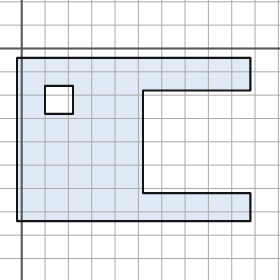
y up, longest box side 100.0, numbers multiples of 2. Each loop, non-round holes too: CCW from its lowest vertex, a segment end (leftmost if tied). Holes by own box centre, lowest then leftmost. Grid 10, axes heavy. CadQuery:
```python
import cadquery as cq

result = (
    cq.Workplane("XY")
    .moveTo(-2.0, -74.0)
    .lineTo(98.0, -74.0)
    .lineTo(98.0, -62.0)
    .lineTo(52.0, -62.0)
    .lineTo(52.0, -18.0)
    .lineTo(98.0, -18.0)
    .lineTo(98.0, -4.0)
    .lineTo(-2.0, -4.0)
    .close()
    .moveTo(10.0, -28.0)
    .lineTo(22.0, -28.0)
    .lineTo(22.0, -16.0)
    .lineTo(10.0, -16.0)
    .close()
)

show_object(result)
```